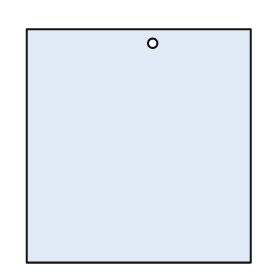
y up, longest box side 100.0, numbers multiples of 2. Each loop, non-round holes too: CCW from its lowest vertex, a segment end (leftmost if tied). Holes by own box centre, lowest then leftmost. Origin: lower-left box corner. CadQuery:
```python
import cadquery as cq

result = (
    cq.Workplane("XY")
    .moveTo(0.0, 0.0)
    .lineTo(96.0, 0.0)
    .lineTo(96.0, 100.0)
    .lineTo(0.0, 100.0)
    .close()
    .moveTo(54.0, 94.0)
    .circle(2.0)
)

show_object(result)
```